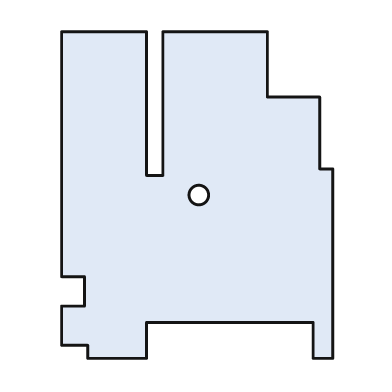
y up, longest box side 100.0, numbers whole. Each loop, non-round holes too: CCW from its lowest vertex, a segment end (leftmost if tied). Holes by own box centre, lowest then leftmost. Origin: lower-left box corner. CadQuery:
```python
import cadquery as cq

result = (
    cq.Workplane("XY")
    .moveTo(8.0, 0.0)
    .lineTo(26.0, 0.0)
    .lineTo(26.0, 11.0)
    .lineTo(77.0, 11.0)
    .lineTo(77.0, 0.0)
    .lineTo(83.0, 0.0)
    .lineTo(83.0, 58.0)
    .lineTo(79.0, 58.0)
    .lineTo(79.0, 80.0)
    .lineTo(63.0, 80.0)
    .lineTo(63.0, 100.0)
    .lineTo(31.0, 100.0)
    .lineTo(31.0, 56.0)
    .lineTo(26.0, 56.0)
    .lineTo(26.0, 100.0)
    .lineTo(0.0, 100.0)
    .lineTo(0.0, 25.0)
    .lineTo(7.0, 25.0)
    .lineTo(7.0, 16.0)
    .lineTo(0.0, 16.0)
    .lineTo(0.0, 4.0)
    .lineTo(8.0, 4.0)
    .close()
    .moveTo(42.0, 50.0)
    .circle(3.0)
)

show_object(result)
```